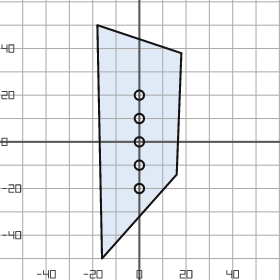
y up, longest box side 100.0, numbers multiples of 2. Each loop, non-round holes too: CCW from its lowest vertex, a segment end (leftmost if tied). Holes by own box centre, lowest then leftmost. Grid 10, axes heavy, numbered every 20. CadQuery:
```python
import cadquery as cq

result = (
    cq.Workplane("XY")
    .moveTo(-16.0, -50.0)
    .lineTo(16.0, -14.0)
    .lineTo(18.0, 38.0)
    .lineTo(-18.0, 50.0)
    .close()
    .moveTo(0.0, -20.0)
    .circle(2.0)
    .moveTo(0.0, -10.0)
    .circle(2.0)
    .moveTo(0.0, 0.0)
    .circle(2.0)
    .moveTo(0.0, 10.0)
    .circle(2.0)
    .moveTo(0.0, 20.0)
    .circle(2.0)
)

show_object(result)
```